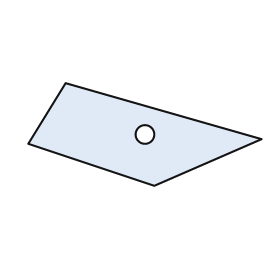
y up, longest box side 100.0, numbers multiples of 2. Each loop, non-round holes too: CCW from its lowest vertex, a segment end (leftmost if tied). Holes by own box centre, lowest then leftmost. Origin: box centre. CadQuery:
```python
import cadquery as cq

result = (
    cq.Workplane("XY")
    .moveTo(4.0, -22.0)
    .lineTo(50.0, -2.0)
    .lineTo(-34.0, 22.0)
    .lineTo(-50.0, -4.0)
    .close()
    .moveTo(0.0, 0.0)
    .circle(4.0)
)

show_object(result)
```